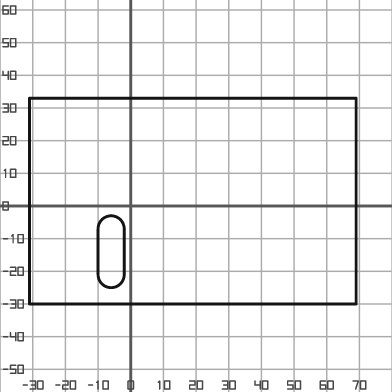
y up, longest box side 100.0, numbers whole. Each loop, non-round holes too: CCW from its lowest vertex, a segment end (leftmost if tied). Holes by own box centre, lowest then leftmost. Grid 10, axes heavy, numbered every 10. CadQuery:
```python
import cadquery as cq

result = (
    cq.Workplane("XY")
    .moveTo(-31.0, -30.0)
    .lineTo(69.0, -30.0)
    .lineTo(69.0, 33.0)
    .lineTo(-31.0, 33.0)
    .close()
    .moveTo(-10.0, -21.0)
    .threePointArc((-6.0, -25.0), (-2.0, -21.0))
    .lineTo(-2.0, -7.0)
    .threePointArc((-6.0, -3.0), (-10.0, -7.0))
    .close()
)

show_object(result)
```